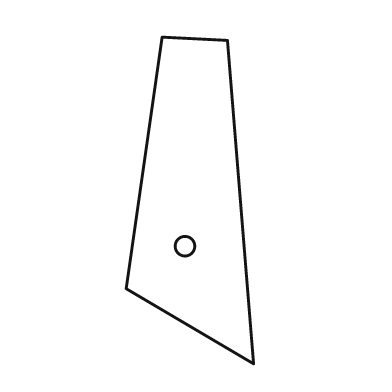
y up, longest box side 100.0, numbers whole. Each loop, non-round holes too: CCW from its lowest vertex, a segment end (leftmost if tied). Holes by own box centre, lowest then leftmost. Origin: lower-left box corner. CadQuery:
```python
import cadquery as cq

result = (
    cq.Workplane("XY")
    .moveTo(39.0, 0.0)
    .lineTo(31.0, 99.0)
    .lineTo(11.0, 100.0)
    .lineTo(0.0, 23.0)
    .close()
    .moveTo(18.0, 36.0)
    .circle(3.0)
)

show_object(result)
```